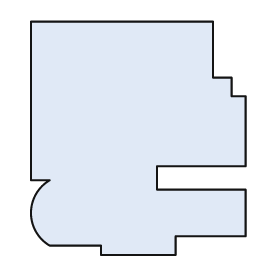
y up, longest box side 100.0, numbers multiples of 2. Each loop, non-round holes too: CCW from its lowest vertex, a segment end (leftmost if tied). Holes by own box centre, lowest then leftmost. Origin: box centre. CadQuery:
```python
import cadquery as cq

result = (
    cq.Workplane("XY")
    .moveTo(-16.0, -50.0)
    .lineTo(16.0, -50.0)
    .lineTo(16.0, -42.0)
    .lineTo(46.0, -42.0)
    .lineTo(46.0, -22.0)
    .lineTo(8.0, -22.0)
    .lineTo(8.0, -12.0)
    .lineTo(46.0, -12.0)
    .lineTo(46.0, 18.0)
    .lineTo(40.0, 18.0)
    .lineTo(40.0, 26.0)
    .lineTo(32.0, 26.0)
    .lineTo(32.0, 50.0)
    .lineTo(-46.0, 50.0)
    .lineTo(-46.0, -18.0)
    .lineTo(-38.0, -18.0)
    .threePointArc((-46.0, -32.0), (-38.0, -46.0))
    .lineTo(-16.0, -46.0)
    .close()
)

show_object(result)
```